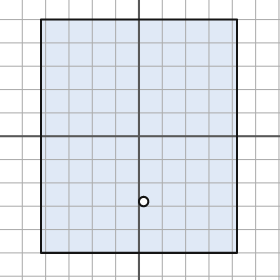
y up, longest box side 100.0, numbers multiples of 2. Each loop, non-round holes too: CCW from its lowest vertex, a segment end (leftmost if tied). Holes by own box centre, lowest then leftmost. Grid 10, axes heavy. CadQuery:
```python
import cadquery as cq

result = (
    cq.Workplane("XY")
    .moveTo(-42.0, -50.0)
    .lineTo(42.0, -50.0)
    .lineTo(42.0, 50.0)
    .lineTo(-42.0, 50.0)
    .close()
    .moveTo(2.0, -28.0)
    .circle(2.0)
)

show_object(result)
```